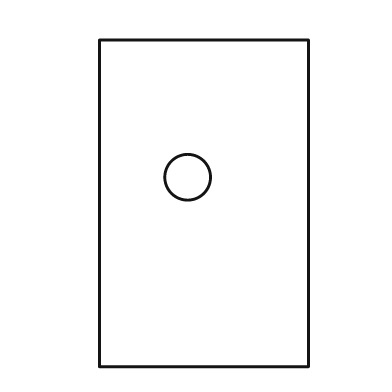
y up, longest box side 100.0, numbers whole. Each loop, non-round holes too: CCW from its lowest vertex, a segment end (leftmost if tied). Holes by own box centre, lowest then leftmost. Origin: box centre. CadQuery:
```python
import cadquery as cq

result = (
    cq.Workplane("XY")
    .moveTo(-32.0, -50.0)
    .lineTo(32.0, -50.0)
    .lineTo(32.0, 50.0)
    .lineTo(-32.0, 50.0)
    .close()
    .moveTo(-5.0, 8.0)
    .circle(7.0)
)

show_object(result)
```